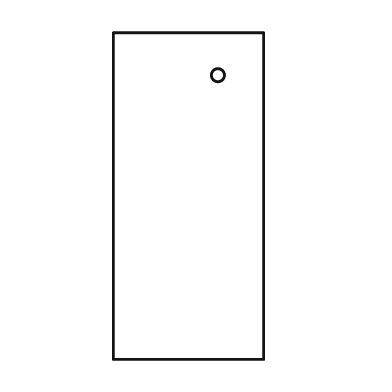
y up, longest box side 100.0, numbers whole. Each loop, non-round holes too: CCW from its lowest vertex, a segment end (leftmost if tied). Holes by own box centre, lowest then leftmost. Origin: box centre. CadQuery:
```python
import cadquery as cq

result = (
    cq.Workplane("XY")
    .moveTo(-23.0, -50.0)
    .lineTo(23.0, -50.0)
    .lineTo(23.0, 50.0)
    .lineTo(-23.0, 50.0)
    .close()
    .moveTo(9.0, 37.0)
    .circle(2.0)
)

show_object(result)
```